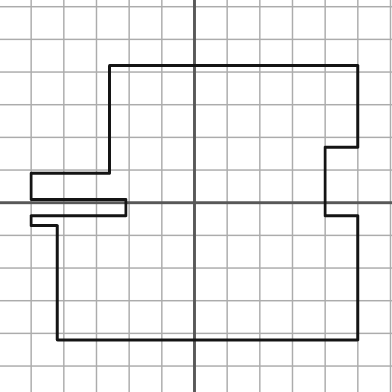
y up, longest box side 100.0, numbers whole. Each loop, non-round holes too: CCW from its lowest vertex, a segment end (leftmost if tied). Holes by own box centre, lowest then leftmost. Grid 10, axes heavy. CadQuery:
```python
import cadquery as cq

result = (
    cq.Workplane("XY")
    .moveTo(-42.0, -42.0)
    .lineTo(50.0, -42.0)
    .lineTo(50.0, -4.0)
    .lineTo(40.0, -4.0)
    .lineTo(40.0, 17.0)
    .lineTo(50.0, 17.0)
    .lineTo(50.0, 42.0)
    .lineTo(-26.0, 42.0)
    .lineTo(-26.0, 9.0)
    .lineTo(-50.0, 9.0)
    .lineTo(-50.0, 1.0)
    .lineTo(-21.0, 1.0)
    .lineTo(-21.0, -4.0)
    .lineTo(-50.0, -4.0)
    .lineTo(-50.0, -7.0)
    .lineTo(-42.0, -7.0)
    .close()
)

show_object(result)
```